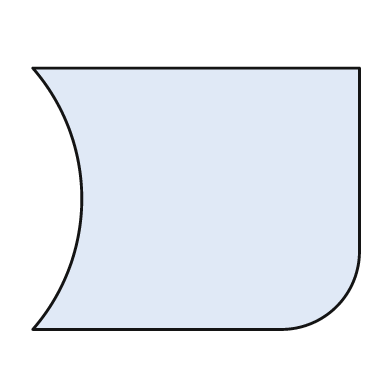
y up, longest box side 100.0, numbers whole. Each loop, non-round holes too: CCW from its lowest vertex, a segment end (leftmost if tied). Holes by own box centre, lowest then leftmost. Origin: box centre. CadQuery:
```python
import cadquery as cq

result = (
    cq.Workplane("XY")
    .moveTo(-50.0, -40.0)
    .lineTo(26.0, -40.0)
    .threePointArc((43.0, -33.0), (50.0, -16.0))
    .lineTo(50.0, 40.0)
    .lineTo(-50.0, 40.0)
    .threePointArc((-35.0, 0.0), (-50.0, -40.0))
    .close()
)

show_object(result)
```